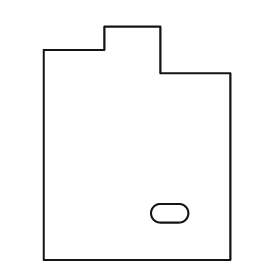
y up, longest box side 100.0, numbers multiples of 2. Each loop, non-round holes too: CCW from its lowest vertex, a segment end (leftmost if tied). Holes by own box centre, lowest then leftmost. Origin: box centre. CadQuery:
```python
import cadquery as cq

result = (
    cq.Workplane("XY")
    .moveTo(-40.0, -50.0)
    .lineTo(40.0, -50.0)
    .lineTo(40.0, 30.0)
    .lineTo(10.0, 30.0)
    .lineTo(10.0, 50.0)
    .lineTo(-14.0, 50.0)
    .lineTo(-14.0, 40.0)
    .lineTo(-40.0, 40.0)
    .close()
    .moveTo(10.0, -34.0)
    .lineTo(18.0, -34.0)
    .threePointArc((22.0, -30.0), (18.0, -26.0))
    .lineTo(10.0, -26.0)
    .threePointArc((6.0, -30.0), (10.0, -34.0))
    .close()
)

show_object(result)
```